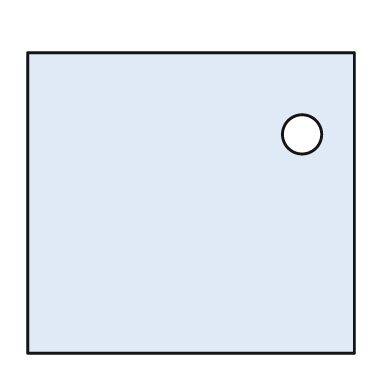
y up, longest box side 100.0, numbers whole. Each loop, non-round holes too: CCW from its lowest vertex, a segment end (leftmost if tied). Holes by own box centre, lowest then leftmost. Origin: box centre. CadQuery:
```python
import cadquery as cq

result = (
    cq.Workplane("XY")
    .moveTo(-50.0, -46.0)
    .lineTo(50.0, -46.0)
    .lineTo(50.0, 46.0)
    .lineTo(-50.0, 46.0)
    .close()
    .moveTo(34.0, 21.0)
    .circle(6.0)
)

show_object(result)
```